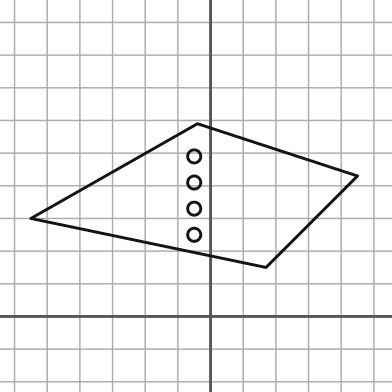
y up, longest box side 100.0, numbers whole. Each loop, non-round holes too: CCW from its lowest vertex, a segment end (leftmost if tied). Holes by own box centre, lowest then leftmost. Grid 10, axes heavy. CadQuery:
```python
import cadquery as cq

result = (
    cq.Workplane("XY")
    .moveTo(17.0, 15.0)
    .lineTo(45.0, 43.0)
    .lineTo(-4.0, 59.0)
    .lineTo(-55.0, 30.0)
    .close()
    .moveTo(-5.0, 25.0)
    .circle(2.0)
    .moveTo(-5.0, 33.0)
    .circle(2.0)
    .moveTo(-5.0, 41.0)
    .circle(2.0)
    .moveTo(-5.0, 49.0)
    .circle(2.0)
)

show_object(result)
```